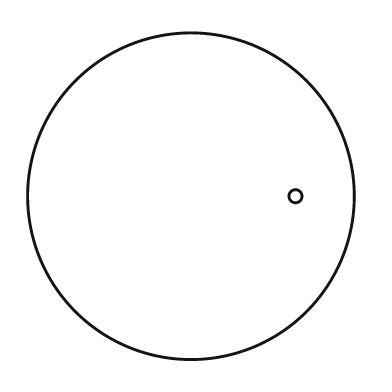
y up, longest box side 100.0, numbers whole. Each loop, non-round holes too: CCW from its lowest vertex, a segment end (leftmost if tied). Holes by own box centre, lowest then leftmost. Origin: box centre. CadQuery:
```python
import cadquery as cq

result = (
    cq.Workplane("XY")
    .moveTo(0.0, 0.0)
    .circle(50.0)
    .moveTo(32.0, 0.0)
    .circle(2.0)
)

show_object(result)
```